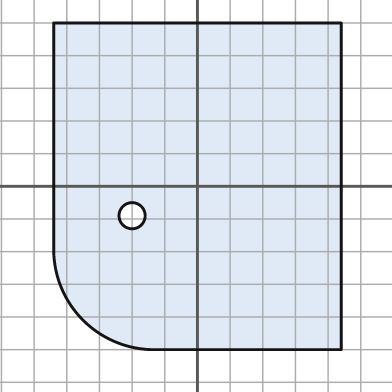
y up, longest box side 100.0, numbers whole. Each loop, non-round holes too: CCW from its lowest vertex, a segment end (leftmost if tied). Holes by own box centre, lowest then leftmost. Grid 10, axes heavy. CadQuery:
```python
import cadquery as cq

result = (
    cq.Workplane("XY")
    .moveTo(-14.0, -50.0)
    .lineTo(44.0, -50.0)
    .lineTo(44.0, 50.0)
    .lineTo(-44.0, 50.0)
    .lineTo(-44.0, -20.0)
    .threePointArc((-35.0, -41.0), (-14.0, -50.0))
    .close()
    .moveTo(-20.0, -9.0)
    .circle(4.0)
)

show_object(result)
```